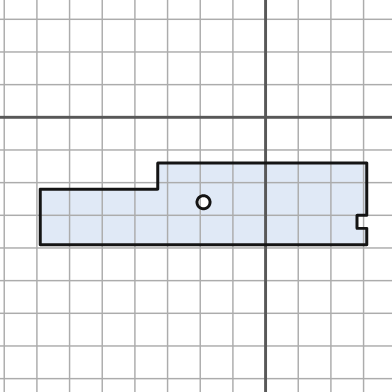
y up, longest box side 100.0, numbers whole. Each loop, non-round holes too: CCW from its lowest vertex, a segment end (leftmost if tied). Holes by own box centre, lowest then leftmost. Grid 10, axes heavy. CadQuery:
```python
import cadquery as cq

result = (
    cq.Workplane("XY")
    .moveTo(-69.0, -39.0)
    .lineTo(31.0, -39.0)
    .lineTo(31.0, -34.0)
    .lineTo(28.0, -34.0)
    .lineTo(28.0, -30.0)
    .lineTo(31.0, -30.0)
    .lineTo(31.0, -14.0)
    .lineTo(-33.0, -14.0)
    .lineTo(-33.0, -22.0)
    .lineTo(-69.0, -22.0)
    .close()
    .moveTo(-19.0, -26.0)
    .circle(2.0)
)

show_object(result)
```